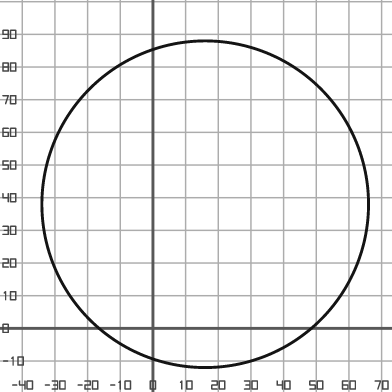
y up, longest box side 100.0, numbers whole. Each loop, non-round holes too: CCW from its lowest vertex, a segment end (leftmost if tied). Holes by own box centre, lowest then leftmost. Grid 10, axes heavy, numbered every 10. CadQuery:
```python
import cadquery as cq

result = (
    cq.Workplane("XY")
    .moveTo(16.0, 38.0)
    .circle(50.0)
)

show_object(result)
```